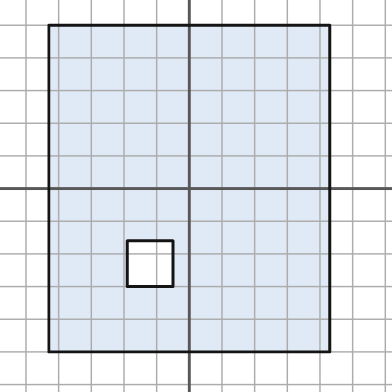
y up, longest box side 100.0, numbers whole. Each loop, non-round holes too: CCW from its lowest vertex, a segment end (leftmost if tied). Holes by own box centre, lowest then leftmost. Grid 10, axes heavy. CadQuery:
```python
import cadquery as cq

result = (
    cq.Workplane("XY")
    .moveTo(-43.0, -50.0)
    .lineTo(43.0, -50.0)
    .lineTo(43.0, 50.0)
    .lineTo(-43.0, 50.0)
    .close()
    .moveTo(-19.0, -30.0)
    .lineTo(-5.0, -30.0)
    .lineTo(-5.0, -16.0)
    .lineTo(-19.0, -16.0)
    .close()
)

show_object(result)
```